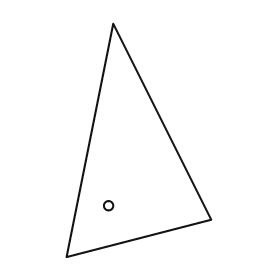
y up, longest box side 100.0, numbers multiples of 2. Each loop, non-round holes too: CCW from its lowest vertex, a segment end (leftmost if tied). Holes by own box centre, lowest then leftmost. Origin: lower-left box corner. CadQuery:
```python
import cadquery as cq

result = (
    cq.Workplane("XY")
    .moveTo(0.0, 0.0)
    .lineTo(62.0, 16.0)
    .lineTo(20.0, 100.0)
    .close()
    .moveTo(18.0, 22.0)
    .circle(2.0)
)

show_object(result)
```